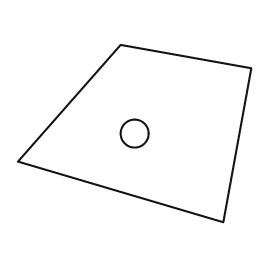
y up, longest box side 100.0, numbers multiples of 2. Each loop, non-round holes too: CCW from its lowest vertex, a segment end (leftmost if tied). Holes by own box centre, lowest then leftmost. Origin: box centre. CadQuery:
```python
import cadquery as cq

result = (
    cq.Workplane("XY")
    .moveTo(38.0, -38.0)
    .lineTo(50.0, 28.0)
    .lineTo(-6.0, 38.0)
    .lineTo(-50.0, -12.0)
    .close()
    .moveTo(0.0, 0.0)
    .circle(6.0)
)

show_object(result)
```